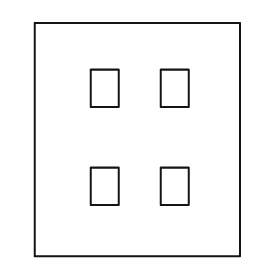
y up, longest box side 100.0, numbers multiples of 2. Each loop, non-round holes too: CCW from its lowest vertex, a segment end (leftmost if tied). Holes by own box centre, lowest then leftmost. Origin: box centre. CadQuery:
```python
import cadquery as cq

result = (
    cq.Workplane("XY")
    .moveTo(-44.0, -50.0)
    .lineTo(44.0, -50.0)
    .lineTo(44.0, 50.0)
    .lineTo(-44.0, 50.0)
    .close()
    .moveTo(-20.0, -28.0)
    .lineTo(-8.0, -28.0)
    .lineTo(-8.0, -12.0)
    .lineTo(-20.0, -12.0)
    .close()
    .moveTo(10.0, -28.0)
    .lineTo(22.0, -28.0)
    .lineTo(22.0, -12.0)
    .lineTo(10.0, -12.0)
    .close()
    .moveTo(-20.0, 14.0)
    .lineTo(-8.0, 14.0)
    .lineTo(-8.0, 30.0)
    .lineTo(-20.0, 30.0)
    .close()
    .moveTo(10.0, 14.0)
    .lineTo(22.0, 14.0)
    .lineTo(22.0, 30.0)
    .lineTo(10.0, 30.0)
    .close()
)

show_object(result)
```